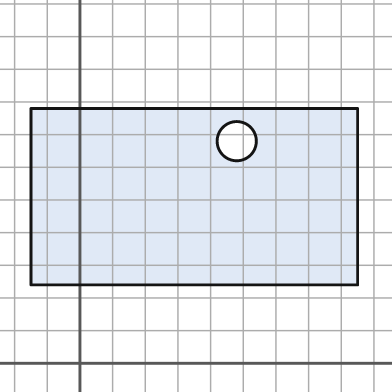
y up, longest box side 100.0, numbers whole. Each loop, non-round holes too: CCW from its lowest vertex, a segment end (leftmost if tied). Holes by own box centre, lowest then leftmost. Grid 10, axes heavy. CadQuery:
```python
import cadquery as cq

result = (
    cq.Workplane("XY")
    .moveTo(-15.0, 24.0)
    .lineTo(85.0, 24.0)
    .lineTo(85.0, 78.0)
    .lineTo(-15.0, 78.0)
    .close()
    .moveTo(48.0, 68.0)
    .circle(6.0)
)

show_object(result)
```